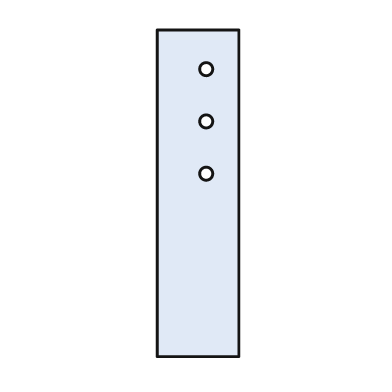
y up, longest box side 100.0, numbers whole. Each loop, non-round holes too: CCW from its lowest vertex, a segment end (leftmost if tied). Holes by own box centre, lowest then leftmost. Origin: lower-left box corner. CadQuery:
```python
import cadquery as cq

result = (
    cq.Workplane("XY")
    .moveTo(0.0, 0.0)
    .lineTo(25.0, 0.0)
    .lineTo(25.0, 100.0)
    .lineTo(0.0, 100.0)
    .close()
    .moveTo(15.0, 56.0)
    .circle(2.0)
    .moveTo(15.0, 72.0)
    .circle(2.0)
    .moveTo(15.0, 88.0)
    .circle(2.0)
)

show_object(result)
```